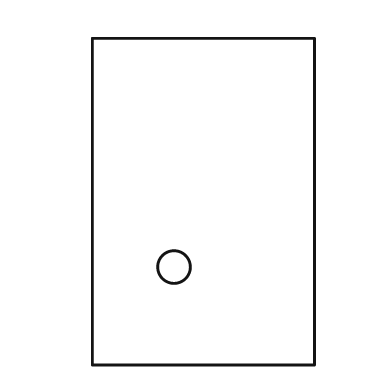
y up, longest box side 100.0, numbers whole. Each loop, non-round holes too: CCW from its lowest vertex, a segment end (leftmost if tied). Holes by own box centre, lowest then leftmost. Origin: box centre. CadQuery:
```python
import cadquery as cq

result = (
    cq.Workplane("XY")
    .moveTo(-34.0, -50.0)
    .lineTo(34.0, -50.0)
    .lineTo(34.0, 50.0)
    .lineTo(-34.0, 50.0)
    .close()
    .moveTo(-9.0, -20.0)
    .circle(5.0)
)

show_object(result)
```